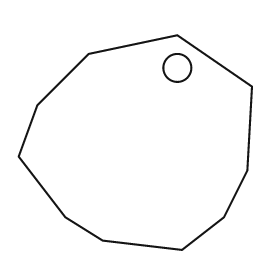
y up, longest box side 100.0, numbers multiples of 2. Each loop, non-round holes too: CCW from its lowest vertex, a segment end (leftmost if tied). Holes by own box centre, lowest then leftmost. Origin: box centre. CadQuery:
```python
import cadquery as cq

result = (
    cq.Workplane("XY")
    .moveTo(20.0, -46.0)
    .lineTo(38.0, -32.0)
    .lineTo(48.0, -12.0)
    .lineTo(50.0, 24.0)
    .lineTo(18.0, 46.0)
    .lineTo(-20.0, 38.0)
    .lineTo(-42.0, 16.0)
    .lineTo(-50.0, -6.0)
    .lineTo(-30.0, -32.0)
    .lineTo(-14.0, -42.0)
    .close()
    .moveTo(18.0, 32.0)
    .circle(6.0)
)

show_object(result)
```